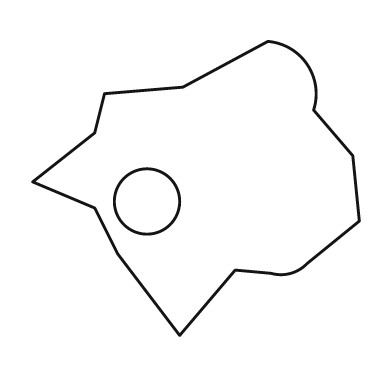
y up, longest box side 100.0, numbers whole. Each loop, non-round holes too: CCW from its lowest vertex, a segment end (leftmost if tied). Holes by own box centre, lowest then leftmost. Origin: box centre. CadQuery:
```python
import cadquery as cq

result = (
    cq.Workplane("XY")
    .moveTo(-5.0, -45.0)
    .lineTo(12.0, -25.0)
    .lineTo(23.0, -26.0)
    .threePointArc((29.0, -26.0), (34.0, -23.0))
    .lineTo(50.0, -10.0)
    .lineTo(48.0, 10.0)
    .lineTo(36.0, 24.0)
    .threePointArc((34.0, 38.0), (22.0, 45.0))
    .lineTo(-4.0, 31.0)
    .lineTo(-28.0, 29.0)
    .lineTo(-31.0, 17.0)
    .lineTo(-50.0, 2.0)
    .lineTo(-31.0, -6.0)
    .lineTo(-24.0, -20.0)
    .close()
    .moveTo(-15.0, -4.0)
    .circle(10.0)
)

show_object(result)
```